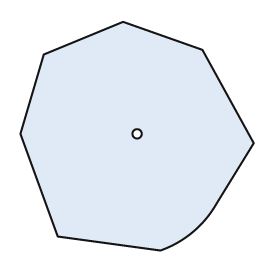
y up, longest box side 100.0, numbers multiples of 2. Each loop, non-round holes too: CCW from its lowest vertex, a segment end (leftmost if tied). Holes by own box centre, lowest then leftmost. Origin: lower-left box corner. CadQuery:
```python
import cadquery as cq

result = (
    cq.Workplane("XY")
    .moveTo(60.0, 0.0)
    .threePointArc((74.0, 8.0), (84.0, 20.0))
    .lineTo(100.0, 46.0)
    .lineTo(78.0, 86.0)
    .lineTo(44.0, 98.0)
    .lineTo(10.0, 84.0)
    .lineTo(0.0, 50.0)
    .lineTo(16.0, 6.0)
    .close()
    .moveTo(50.0, 50.0)
    .circle(2.0)
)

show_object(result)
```